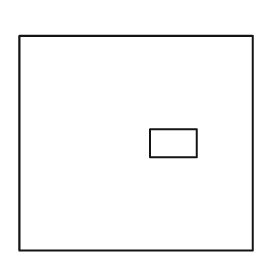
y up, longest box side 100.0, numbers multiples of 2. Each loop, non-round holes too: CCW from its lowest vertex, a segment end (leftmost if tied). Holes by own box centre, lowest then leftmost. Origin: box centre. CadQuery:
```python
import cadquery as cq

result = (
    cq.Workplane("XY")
    .moveTo(-50.0, -46.0)
    .lineTo(50.0, -46.0)
    .lineTo(50.0, 46.0)
    .lineTo(-50.0, 46.0)
    .close()
    .moveTo(6.0, -6.0)
    .lineTo(26.0, -6.0)
    .lineTo(26.0, 6.0)
    .lineTo(6.0, 6.0)
    .close()
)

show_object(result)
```